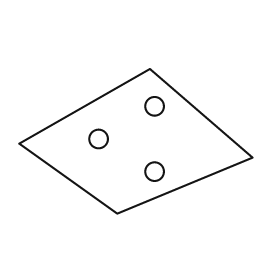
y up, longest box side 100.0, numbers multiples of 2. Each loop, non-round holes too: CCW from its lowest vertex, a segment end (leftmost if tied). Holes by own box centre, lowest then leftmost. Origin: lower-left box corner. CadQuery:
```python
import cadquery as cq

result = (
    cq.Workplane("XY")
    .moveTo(42.0, 0.0)
    .lineTo(100.0, 24.0)
    .lineTo(56.0, 62.0)
    .lineTo(0.0, 30.0)
    .close()
    .moveTo(58.0, 18.0)
    .circle(4.0)
    .moveTo(34.0, 32.0)
    .circle(4.0)
    .moveTo(58.0, 46.0)
    .circle(4.0)
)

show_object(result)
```